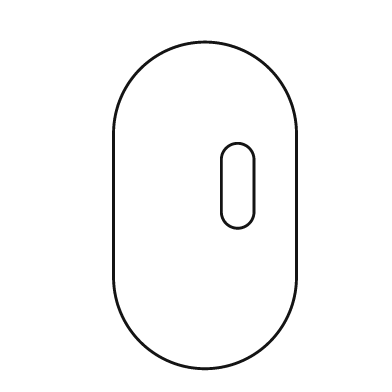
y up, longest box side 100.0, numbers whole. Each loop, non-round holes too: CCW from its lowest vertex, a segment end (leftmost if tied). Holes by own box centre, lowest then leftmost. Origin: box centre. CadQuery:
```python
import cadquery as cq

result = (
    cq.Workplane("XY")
    .moveTo(-28.0, -22.0)
    .threePointArc((0.0, -50.0), (28.0, -22.0))
    .lineTo(28.0, 22.0)
    .threePointArc((0.0, 50.0), (-28.0, 22.0))
    .close()
    .moveTo(5.0, -2.0)
    .threePointArc((10.0, -7.0), (15.0, -2.0))
    .lineTo(15.0, 14.0)
    .threePointArc((10.0, 19.0), (5.0, 14.0))
    .close()
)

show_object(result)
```